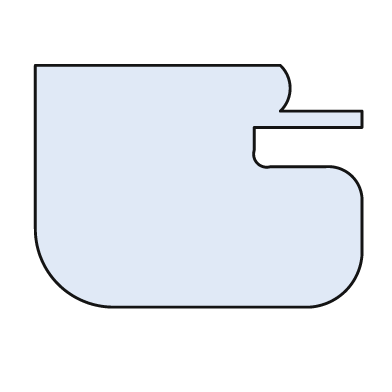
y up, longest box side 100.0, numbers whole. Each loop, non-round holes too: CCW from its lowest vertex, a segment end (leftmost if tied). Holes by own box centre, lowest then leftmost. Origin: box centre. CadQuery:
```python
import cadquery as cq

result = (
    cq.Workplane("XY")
    .moveTo(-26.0, -37.0)
    .lineTo(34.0, -37.0)
    .threePointArc((45.0, -32.0), (50.0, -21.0))
    .lineTo(50.0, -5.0)
    .threePointArc((47.0, 3.0), (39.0, 6.0))
    .lineTo(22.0, 6.0)
    .threePointArc((18.0, 7.0), (17.0, 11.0))
    .lineTo(17.0, 18.0)
    .lineTo(50.0, 18.0)
    .lineTo(50.0, 23.0)
    .lineTo(25.0, 23.0)
    .threePointArc((28.0, 30.0), (25.0, 37.0))
    .lineTo(-50.0, 37.0)
    .lineTo(-50.0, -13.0)
    .threePointArc((-43.0, -30.0), (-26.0, -37.0))
    .close()
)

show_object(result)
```